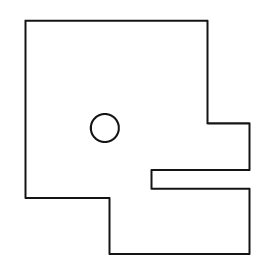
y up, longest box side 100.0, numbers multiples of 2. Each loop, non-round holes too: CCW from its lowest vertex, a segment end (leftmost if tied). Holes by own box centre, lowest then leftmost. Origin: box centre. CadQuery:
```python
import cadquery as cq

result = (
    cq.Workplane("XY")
    .moveTo(-12.0, -50.0)
    .lineTo(48.0, -50.0)
    .lineTo(48.0, -22.0)
    .lineTo(6.0, -22.0)
    .lineTo(6.0, -14.0)
    .lineTo(48.0, -14.0)
    .lineTo(48.0, 6.0)
    .lineTo(30.0, 6.0)
    .lineTo(30.0, 50.0)
    .lineTo(-48.0, 50.0)
    .lineTo(-48.0, -26.0)
    .lineTo(-12.0, -26.0)
    .close()
    .moveTo(-14.0, 4.0)
    .circle(6.0)
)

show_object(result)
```